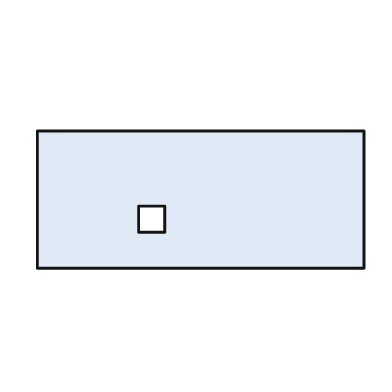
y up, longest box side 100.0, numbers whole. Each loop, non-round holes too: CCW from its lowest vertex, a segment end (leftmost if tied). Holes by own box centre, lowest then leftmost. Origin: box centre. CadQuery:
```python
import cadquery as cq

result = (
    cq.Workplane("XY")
    .moveTo(-50.0, -21.0)
    .lineTo(50.0, -21.0)
    .lineTo(50.0, 21.0)
    .lineTo(-50.0, 21.0)
    .close()
    .moveTo(-19.0, -10.0)
    .lineTo(-11.0, -10.0)
    .lineTo(-11.0, -2.0)
    .lineTo(-19.0, -2.0)
    .close()
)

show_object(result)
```